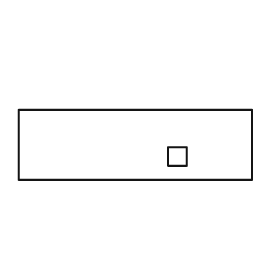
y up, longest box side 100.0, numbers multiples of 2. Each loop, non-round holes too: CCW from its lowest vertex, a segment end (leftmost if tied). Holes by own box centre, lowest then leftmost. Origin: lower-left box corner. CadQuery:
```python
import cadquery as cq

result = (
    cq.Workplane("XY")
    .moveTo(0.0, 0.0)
    .lineTo(100.0, 0.0)
    .lineTo(100.0, 30.0)
    .lineTo(0.0, 30.0)
    .close()
    .moveTo(64.0, 6.0)
    .lineTo(72.0, 6.0)
    .lineTo(72.0, 14.0)
    .lineTo(64.0, 14.0)
    .close()
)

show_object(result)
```